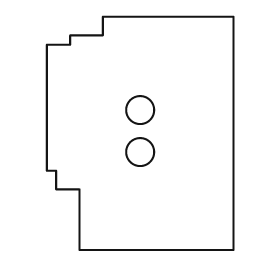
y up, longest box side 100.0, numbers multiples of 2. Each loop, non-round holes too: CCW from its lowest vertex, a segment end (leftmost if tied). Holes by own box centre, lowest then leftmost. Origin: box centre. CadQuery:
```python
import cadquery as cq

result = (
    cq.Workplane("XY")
    .moveTo(-26.0, -50.0)
    .lineTo(40.0, -50.0)
    .lineTo(40.0, 50.0)
    .lineTo(-16.0, 50.0)
    .lineTo(-16.0, 42.0)
    .lineTo(-30.0, 42.0)
    .lineTo(-30.0, 38.0)
    .lineTo(-40.0, 38.0)
    .lineTo(-40.0, -16.0)
    .lineTo(-36.0, -16.0)
    .lineTo(-36.0, -24.0)
    .lineTo(-26.0, -24.0)
    .close()
    .moveTo(0.0, -8.0)
    .circle(6.0)
    .moveTo(0.0, 10.0)
    .circle(6.0)
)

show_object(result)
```